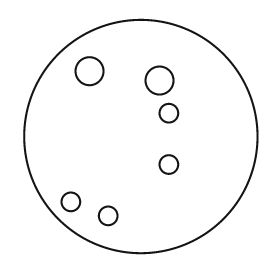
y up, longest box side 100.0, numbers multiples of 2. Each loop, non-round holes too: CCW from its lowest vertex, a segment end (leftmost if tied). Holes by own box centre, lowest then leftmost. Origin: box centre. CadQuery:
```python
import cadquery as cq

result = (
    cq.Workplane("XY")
    .moveTo(0.0, 0.0)
    .circle(50.0)
    .moveTo(-14.0, -34.0)
    .circle(4.0)
    .moveTo(-30.0, -28.0)
    .circle(4.0)
    .moveTo(12.0, -12.0)
    .circle(4.0)
    .moveTo(12.0, 10.0)
    .circle(4.0)
    .moveTo(8.0, 24.0)
    .circle(6.0)
    .moveTo(-22.0, 28.0)
    .circle(6.0)
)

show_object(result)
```